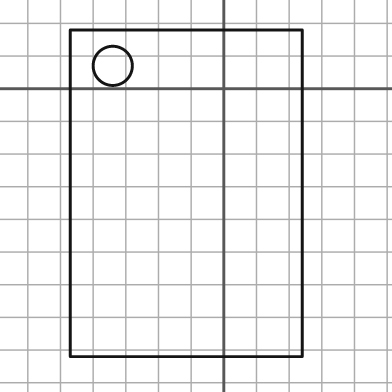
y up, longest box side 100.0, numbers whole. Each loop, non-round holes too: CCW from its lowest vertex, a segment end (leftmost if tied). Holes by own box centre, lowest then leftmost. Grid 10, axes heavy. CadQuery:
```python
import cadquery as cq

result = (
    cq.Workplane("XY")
    .moveTo(-47.0, -82.0)
    .lineTo(24.0, -82.0)
    .lineTo(24.0, 18.0)
    .lineTo(-47.0, 18.0)
    .close()
    .moveTo(-34.0, 7.0)
    .circle(6.0)
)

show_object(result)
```